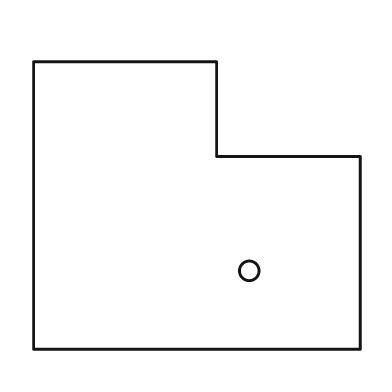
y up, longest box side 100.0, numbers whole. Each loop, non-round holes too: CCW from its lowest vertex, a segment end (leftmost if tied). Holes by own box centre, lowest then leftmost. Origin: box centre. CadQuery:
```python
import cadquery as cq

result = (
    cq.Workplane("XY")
    .moveTo(-50.0, -44.0)
    .lineTo(50.0, -44.0)
    .lineTo(50.0, 15.0)
    .lineTo(6.0, 15.0)
    .lineTo(6.0, 44.0)
    .lineTo(-50.0, 44.0)
    .close()
    .moveTo(16.0, -20.0)
    .circle(3.0)
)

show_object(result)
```